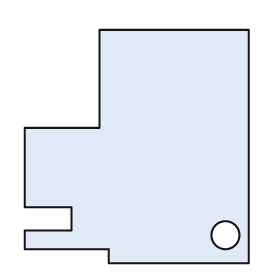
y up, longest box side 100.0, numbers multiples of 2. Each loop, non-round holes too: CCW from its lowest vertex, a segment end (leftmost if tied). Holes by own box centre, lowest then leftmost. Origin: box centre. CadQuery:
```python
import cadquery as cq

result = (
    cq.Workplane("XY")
    .moveTo(-12.0, -50.0)
    .lineTo(48.0, -50.0)
    .lineTo(48.0, 50.0)
    .lineTo(-16.0, 50.0)
    .lineTo(-16.0, 8.0)
    .lineTo(-48.0, 8.0)
    .lineTo(-48.0, -26.0)
    .lineTo(-28.0, -26.0)
    .lineTo(-28.0, -36.0)
    .lineTo(-48.0, -36.0)
    .lineTo(-48.0, -44.0)
    .lineTo(-12.0, -44.0)
    .close()
    .moveTo(38.0, -38.0)
    .circle(6.0)
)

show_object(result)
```